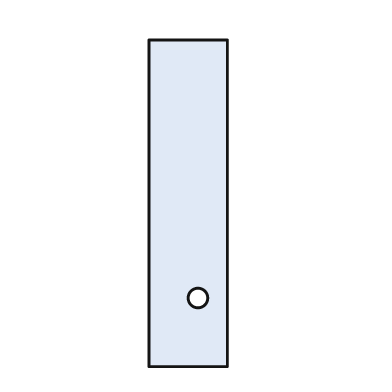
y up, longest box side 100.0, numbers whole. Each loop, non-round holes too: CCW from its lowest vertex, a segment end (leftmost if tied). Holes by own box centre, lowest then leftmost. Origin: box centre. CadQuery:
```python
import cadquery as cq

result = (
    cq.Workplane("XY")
    .moveTo(-12.0, -50.0)
    .lineTo(12.0, -50.0)
    .lineTo(12.0, 50.0)
    .lineTo(-12.0, 50.0)
    .close()
    .moveTo(3.0, -29.0)
    .circle(3.0)
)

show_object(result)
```